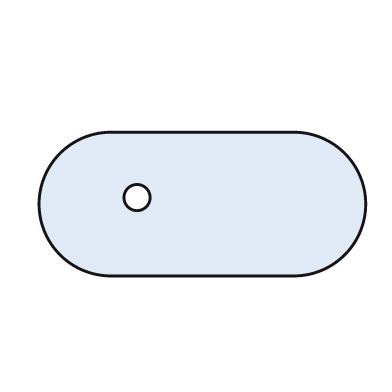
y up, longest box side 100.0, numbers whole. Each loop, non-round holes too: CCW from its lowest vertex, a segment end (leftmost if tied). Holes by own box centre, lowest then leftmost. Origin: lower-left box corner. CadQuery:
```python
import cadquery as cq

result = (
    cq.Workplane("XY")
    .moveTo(22.0, 0.0)
    .lineTo(78.0, 0.0)
    .threePointArc((100.0, 22.0), (78.0, 44.0))
    .lineTo(22.0, 44.0)
    .threePointArc((0.0, 22.0), (22.0, 0.0))
    .close()
    .moveTo(30.0, 24.0)
    .circle(4.0)
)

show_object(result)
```